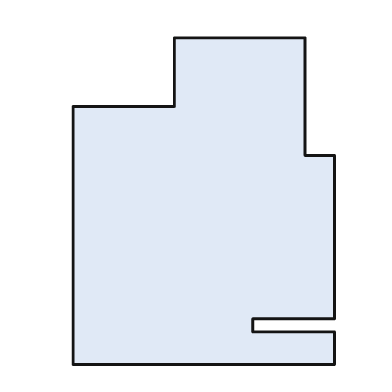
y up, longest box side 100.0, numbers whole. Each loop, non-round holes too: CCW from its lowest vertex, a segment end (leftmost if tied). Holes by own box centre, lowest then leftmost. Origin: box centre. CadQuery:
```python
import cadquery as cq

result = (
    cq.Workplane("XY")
    .moveTo(-40.0, -50.0)
    .lineTo(40.0, -50.0)
    .lineTo(40.0, -40.0)
    .lineTo(15.0, -40.0)
    .lineTo(15.0, -36.0)
    .lineTo(40.0, -36.0)
    .lineTo(40.0, 14.0)
    .lineTo(31.0, 14.0)
    .lineTo(31.0, 50.0)
    .lineTo(-9.0, 50.0)
    .lineTo(-9.0, 29.0)
    .lineTo(-40.0, 29.0)
    .close()
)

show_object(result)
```